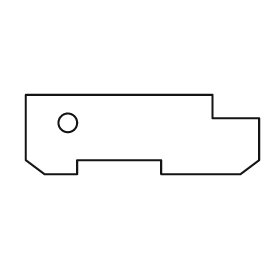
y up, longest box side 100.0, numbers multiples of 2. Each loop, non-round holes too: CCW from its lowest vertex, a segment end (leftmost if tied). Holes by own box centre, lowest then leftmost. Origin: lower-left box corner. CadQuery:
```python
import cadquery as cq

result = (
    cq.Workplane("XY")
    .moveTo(8.0, 0.0)
    .lineTo(22.0, 0.0)
    .lineTo(22.0, 6.0)
    .lineTo(58.0, 6.0)
    .lineTo(58.0, 0.0)
    .lineTo(92.0, 0.0)
    .lineTo(100.0, 6.0)
    .lineTo(100.0, 24.0)
    .lineTo(80.0, 24.0)
    .lineTo(80.0, 34.0)
    .lineTo(0.0, 34.0)
    .lineTo(0.0, 6.0)
    .close()
    .moveTo(18.0, 22.0)
    .circle(4.0)
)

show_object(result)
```